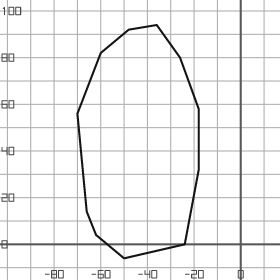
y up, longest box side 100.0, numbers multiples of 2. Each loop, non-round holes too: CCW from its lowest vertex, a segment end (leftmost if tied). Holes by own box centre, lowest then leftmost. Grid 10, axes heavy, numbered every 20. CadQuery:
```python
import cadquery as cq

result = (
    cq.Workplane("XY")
    .moveTo(-50.0, -6.0)
    .lineTo(-24.0, 0.0)
    .lineTo(-18.0, 32.0)
    .lineTo(-18.0, 58.0)
    .lineTo(-26.0, 80.0)
    .lineTo(-36.0, 94.0)
    .lineTo(-48.0, 92.0)
    .lineTo(-60.0, 82.0)
    .lineTo(-70.0, 56.0)
    .lineTo(-66.0, 14.0)
    .lineTo(-62.0, 4.0)
    .close()
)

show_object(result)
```